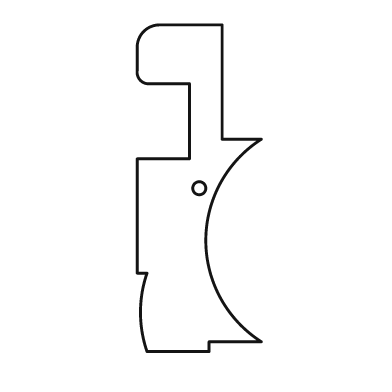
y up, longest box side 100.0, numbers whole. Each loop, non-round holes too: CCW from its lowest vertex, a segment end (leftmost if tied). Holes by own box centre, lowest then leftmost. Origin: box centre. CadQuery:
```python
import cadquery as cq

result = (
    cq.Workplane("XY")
    .moveTo(-16.0, -50.0)
    .lineTo(3.0, -50.0)
    .lineTo(3.0, -47.0)
    .lineTo(19.0, -47.0)
    .threePointArc((2.0, -16.0), (19.0, 15.0))
    .lineTo(7.0, 15.0)
    .lineTo(7.0, 50.0)
    .lineTo(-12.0, 50.0)
    .threePointArc((-17.0, 48.0), (-19.0, 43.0))
    .lineTo(-19.0, 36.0)
    .threePointArc((-18.0, 33.0), (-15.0, 32.0))
    .lineTo(-3.0, 32.0)
    .lineTo(-3.0, 9.0)
    .lineTo(-19.0, 9.0)
    .lineTo(-19.0, -26.0)
    .lineTo(-16.0, -26.0)
    .threePointArc((-18.0, -38.0), (-16.0, -50.0))
    .close()
    .moveTo(0.0, 0.0)
    .circle(2.0)
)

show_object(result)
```